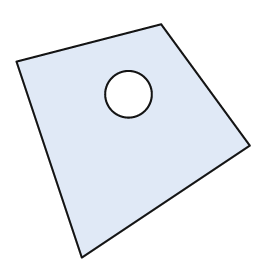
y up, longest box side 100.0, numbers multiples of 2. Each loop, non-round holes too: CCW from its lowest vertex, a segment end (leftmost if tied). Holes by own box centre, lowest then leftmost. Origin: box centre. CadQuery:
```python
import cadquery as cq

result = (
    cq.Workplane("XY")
    .moveTo(-22.0, -50.0)
    .lineTo(50.0, -2.0)
    .lineTo(12.0, 50.0)
    .lineTo(-50.0, 34.0)
    .close()
    .moveTo(-2.0, 20.0)
    .circle(10.0)
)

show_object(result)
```